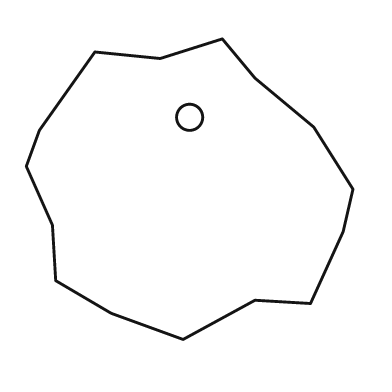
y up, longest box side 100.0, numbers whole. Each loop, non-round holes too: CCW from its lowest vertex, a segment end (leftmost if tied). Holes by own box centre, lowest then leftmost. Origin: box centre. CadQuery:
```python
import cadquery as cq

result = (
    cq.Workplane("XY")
    .moveTo(-2.0, -46.0)
    .lineTo(20.0, -34.0)
    .lineTo(37.0, -35.0)
    .lineTo(47.0, -13.0)
    .lineTo(50.0, 0.0)
    .lineTo(38.0, 19.0)
    .lineTo(20.0, 34.0)
    .lineTo(10.0, 46.0)
    .lineTo(-9.0, 40.0)
    .lineTo(-29.0, 42.0)
    .lineTo(-46.0, 18.0)
    .lineTo(-50.0, 7.0)
    .lineTo(-42.0, -11.0)
    .lineTo(-41.0, -28.0)
    .lineTo(-24.0, -38.0)
    .close()
    .moveTo(0.0, 22.0)
    .circle(4.0)
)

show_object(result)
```